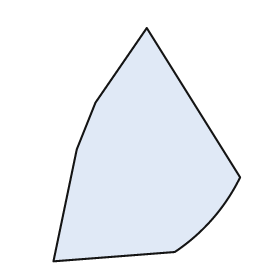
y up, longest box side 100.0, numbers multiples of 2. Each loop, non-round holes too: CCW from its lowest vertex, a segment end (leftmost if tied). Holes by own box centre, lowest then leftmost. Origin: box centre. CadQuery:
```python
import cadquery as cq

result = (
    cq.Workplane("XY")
    .moveTo(-40.0, -50.0)
    .lineTo(12.0, -46.0)
    .threePointArc((28.0, -32.0), (40.0, -14.0))
    .lineTo(0.0, 50.0)
    .lineTo(-22.0, 18.0)
    .lineTo(-30.0, -2.0)
    .close()
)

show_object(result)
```